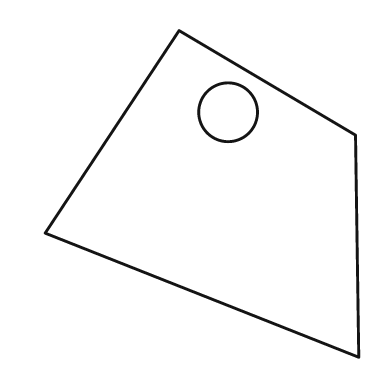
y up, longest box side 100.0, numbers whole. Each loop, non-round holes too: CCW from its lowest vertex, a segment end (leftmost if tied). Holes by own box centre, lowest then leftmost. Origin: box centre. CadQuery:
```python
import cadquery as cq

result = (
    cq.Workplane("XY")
    .moveTo(48.0, -50.0)
    .lineTo(47.0, 18.0)
    .lineTo(-7.0, 50.0)
    .lineTo(-48.0, -12.0)
    .close()
    .moveTo(8.0, 25.0)
    .circle(9.0)
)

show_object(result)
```